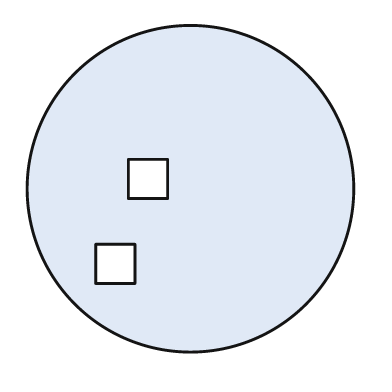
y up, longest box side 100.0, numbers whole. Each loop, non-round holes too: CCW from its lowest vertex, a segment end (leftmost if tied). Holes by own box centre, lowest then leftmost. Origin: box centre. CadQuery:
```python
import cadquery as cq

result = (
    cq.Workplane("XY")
    .moveTo(0.0, 0.0)
    .circle(50.0)
    .moveTo(-29.0, -29.0)
    .lineTo(-17.0, -29.0)
    .lineTo(-17.0, -17.0)
    .lineTo(-29.0, -17.0)
    .close()
    .moveTo(-19.0, -3.0)
    .lineTo(-7.0, -3.0)
    .lineTo(-7.0, 9.0)
    .lineTo(-19.0, 9.0)
    .close()
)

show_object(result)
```